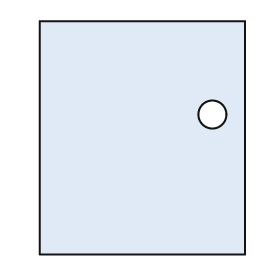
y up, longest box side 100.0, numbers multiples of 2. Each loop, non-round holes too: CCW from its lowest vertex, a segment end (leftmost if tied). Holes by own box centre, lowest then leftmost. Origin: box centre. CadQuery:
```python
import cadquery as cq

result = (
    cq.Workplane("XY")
    .moveTo(-44.0, -50.0)
    .lineTo(44.0, -50.0)
    .lineTo(44.0, 50.0)
    .lineTo(-44.0, 50.0)
    .close()
    .moveTo(30.0, 10.0)
    .circle(6.0)
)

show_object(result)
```